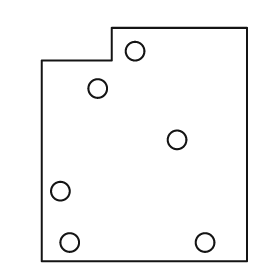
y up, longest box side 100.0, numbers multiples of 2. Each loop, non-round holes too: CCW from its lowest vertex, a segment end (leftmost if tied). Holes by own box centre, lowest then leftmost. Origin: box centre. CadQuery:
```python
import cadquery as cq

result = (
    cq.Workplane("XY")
    .moveTo(-44.0, -50.0)
    .lineTo(44.0, -50.0)
    .lineTo(44.0, 50.0)
    .lineTo(-14.0, 50.0)
    .lineTo(-14.0, 36.0)
    .lineTo(-44.0, 36.0)
    .close()
    .moveTo(-32.0, -42.0)
    .circle(4.0)
    .moveTo(26.0, -42.0)
    .circle(4.0)
    .moveTo(-36.0, -20.0)
    .circle(4.0)
    .moveTo(14.0, 2.0)
    .circle(4.0)
    .moveTo(-20.0, 24.0)
    .circle(4.0)
    .moveTo(-4.0, 40.0)
    .circle(4.0)
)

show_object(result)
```